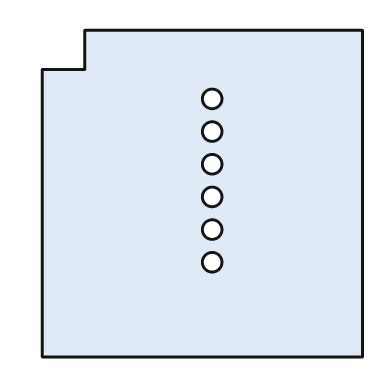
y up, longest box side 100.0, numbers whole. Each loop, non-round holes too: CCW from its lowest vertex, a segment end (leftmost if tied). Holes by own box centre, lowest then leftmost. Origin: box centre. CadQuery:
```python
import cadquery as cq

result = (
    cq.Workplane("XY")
    .moveTo(-49.0, -50.0)
    .lineTo(49.0, -50.0)
    .lineTo(49.0, 50.0)
    .lineTo(-36.0, 50.0)
    .lineTo(-36.0, 38.0)
    .lineTo(-49.0, 38.0)
    .close()
    .moveTo(3.0, -21.0)
    .circle(3.0)
    .moveTo(3.0, -11.0)
    .circle(3.0)
    .moveTo(3.0, -1.0)
    .circle(3.0)
    .moveTo(3.0, 9.0)
    .circle(3.0)
    .moveTo(3.0, 19.0)
    .circle(3.0)
    .moveTo(3.0, 29.0)
    .circle(3.0)
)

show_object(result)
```